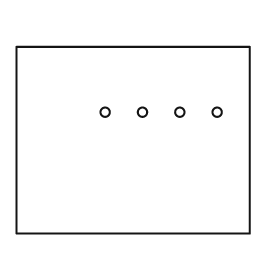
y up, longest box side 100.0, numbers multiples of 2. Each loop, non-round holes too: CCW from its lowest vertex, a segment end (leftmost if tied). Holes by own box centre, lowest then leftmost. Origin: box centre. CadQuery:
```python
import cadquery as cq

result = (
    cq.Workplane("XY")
    .moveTo(-50.0, -40.0)
    .lineTo(50.0, -40.0)
    .lineTo(50.0, 40.0)
    .lineTo(-50.0, 40.0)
    .close()
    .moveTo(-12.0, 12.0)
    .circle(2.0)
    .moveTo(4.0, 12.0)
    .circle(2.0)
    .moveTo(20.0, 12.0)
    .circle(2.0)
    .moveTo(36.0, 12.0)
    .circle(2.0)
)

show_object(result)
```